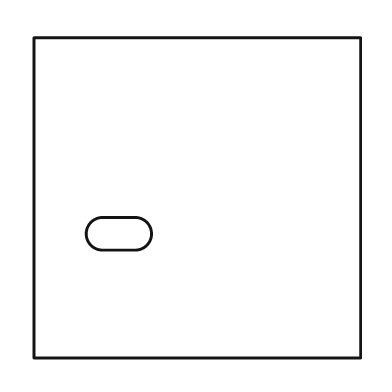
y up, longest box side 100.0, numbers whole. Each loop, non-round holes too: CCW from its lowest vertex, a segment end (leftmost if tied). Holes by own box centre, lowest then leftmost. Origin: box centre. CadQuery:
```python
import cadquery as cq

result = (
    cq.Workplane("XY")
    .moveTo(-50.0, -49.0)
    .lineTo(50.0, -49.0)
    .lineTo(50.0, 49.0)
    .lineTo(-50.0, 49.0)
    .close()
    .moveTo(-29.0, -16.0)
    .lineTo(-19.0, -16.0)
    .threePointArc((-14.0, -11.0), (-19.0, -6.0))
    .lineTo(-29.0, -6.0)
    .threePointArc((-34.0, -11.0), (-29.0, -16.0))
    .close()
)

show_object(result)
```